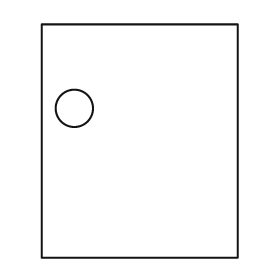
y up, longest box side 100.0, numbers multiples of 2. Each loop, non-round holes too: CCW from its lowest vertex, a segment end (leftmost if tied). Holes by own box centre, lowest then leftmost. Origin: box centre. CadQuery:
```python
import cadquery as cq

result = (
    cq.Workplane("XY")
    .moveTo(-42.0, -50.0)
    .lineTo(42.0, -50.0)
    .lineTo(42.0, 50.0)
    .lineTo(-42.0, 50.0)
    .close()
    .moveTo(-28.0, 14.0)
    .circle(8.0)
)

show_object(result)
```